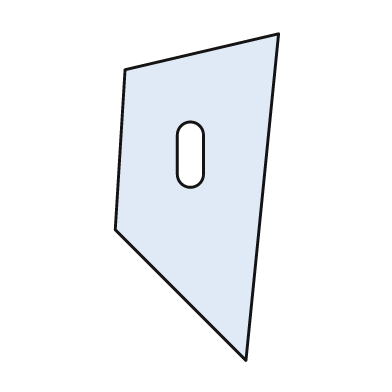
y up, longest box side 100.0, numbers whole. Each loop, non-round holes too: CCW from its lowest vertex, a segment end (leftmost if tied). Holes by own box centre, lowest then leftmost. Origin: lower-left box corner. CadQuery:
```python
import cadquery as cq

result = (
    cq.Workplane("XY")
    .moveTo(40.0, 0.0)
    .lineTo(50.0, 100.0)
    .lineTo(3.0, 89.0)
    .lineTo(0.0, 40.0)
    .close()
    .moveTo(19.0, 57.0)
    .threePointArc((23.0, 53.0), (27.0, 57.0))
    .lineTo(27.0, 69.0)
    .threePointArc((23.0, 73.0), (19.0, 69.0))
    .close()
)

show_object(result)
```